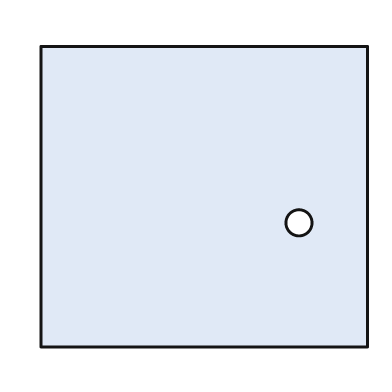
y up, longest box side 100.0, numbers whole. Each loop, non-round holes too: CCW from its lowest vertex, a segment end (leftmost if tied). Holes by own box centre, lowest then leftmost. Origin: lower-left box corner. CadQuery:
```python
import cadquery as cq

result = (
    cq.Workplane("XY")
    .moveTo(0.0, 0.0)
    .lineTo(100.0, 0.0)
    .lineTo(100.0, 92.0)
    .lineTo(0.0, 92.0)
    .close()
    .moveTo(79.0, 38.0)
    .circle(4.0)
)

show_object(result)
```